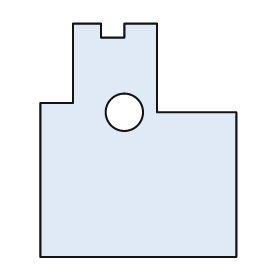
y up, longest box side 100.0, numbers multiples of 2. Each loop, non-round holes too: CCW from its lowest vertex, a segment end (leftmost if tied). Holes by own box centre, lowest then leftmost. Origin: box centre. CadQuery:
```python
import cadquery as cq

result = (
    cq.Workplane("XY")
    .moveTo(-42.0, -50.0)
    .lineTo(42.0, -50.0)
    .lineTo(42.0, 12.0)
    .lineTo(8.0, 12.0)
    .lineTo(8.0, 50.0)
    .lineTo(-6.0, 50.0)
    .lineTo(-6.0, 44.0)
    .lineTo(-16.0, 44.0)
    .lineTo(-16.0, 50.0)
    .lineTo(-28.0, 50.0)
    .lineTo(-28.0, 16.0)
    .lineTo(-42.0, 16.0)
    .close()
    .moveTo(-6.0, 12.0)
    .circle(8.0)
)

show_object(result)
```